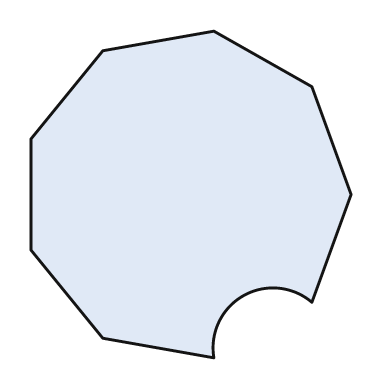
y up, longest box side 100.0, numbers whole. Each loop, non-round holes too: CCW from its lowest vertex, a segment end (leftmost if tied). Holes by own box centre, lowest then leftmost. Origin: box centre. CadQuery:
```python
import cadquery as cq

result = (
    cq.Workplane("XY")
    .moveTo(7.0, -50.0)
    .threePointArc((16.0, -31.0), (37.0, -33.0))
    .lineTo(49.0, 0.0)
    .lineTo(37.0, 33.0)
    .lineTo(7.0, 50.0)
    .lineTo(-27.0, 44.0)
    .lineTo(-49.0, 17.0)
    .lineTo(-49.0, -17.0)
    .lineTo(-27.0, -44.0)
    .close()
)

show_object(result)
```